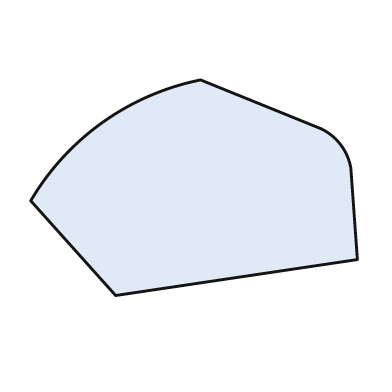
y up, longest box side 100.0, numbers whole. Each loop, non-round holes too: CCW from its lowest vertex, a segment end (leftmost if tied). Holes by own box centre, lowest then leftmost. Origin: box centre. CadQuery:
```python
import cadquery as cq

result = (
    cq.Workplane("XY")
    .moveTo(-24.0, -33.0)
    .lineTo(50.0, -22.0)
    .lineTo(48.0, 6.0)
    .threePointArc((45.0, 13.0), (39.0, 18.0))
    .lineTo(2.0, 33.0)
    .threePointArc((-28.0, 20.0), (-50.0, -4.0))
    .close()
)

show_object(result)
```